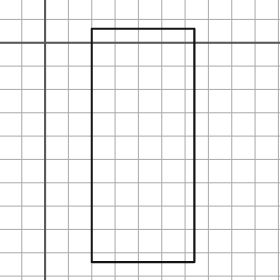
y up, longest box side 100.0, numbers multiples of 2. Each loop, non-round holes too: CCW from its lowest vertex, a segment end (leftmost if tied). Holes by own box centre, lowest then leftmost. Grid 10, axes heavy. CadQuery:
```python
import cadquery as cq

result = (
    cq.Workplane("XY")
    .moveTo(20.0, -94.0)
    .lineTo(64.0, -94.0)
    .lineTo(64.0, 6.0)
    .lineTo(20.0, 6.0)
    .close()
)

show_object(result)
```